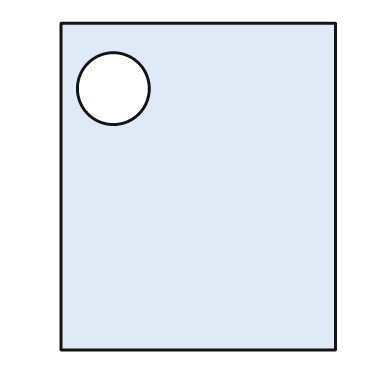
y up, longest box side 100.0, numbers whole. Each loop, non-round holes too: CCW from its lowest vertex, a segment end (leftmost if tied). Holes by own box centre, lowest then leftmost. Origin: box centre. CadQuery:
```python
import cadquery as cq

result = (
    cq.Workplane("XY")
    .moveTo(-42.0, -50.0)
    .lineTo(42.0, -50.0)
    .lineTo(42.0, 50.0)
    .lineTo(-42.0, 50.0)
    .close()
    .moveTo(-26.0, 30.0)
    .circle(11.0)
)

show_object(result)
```